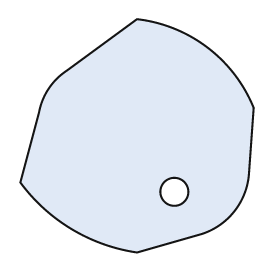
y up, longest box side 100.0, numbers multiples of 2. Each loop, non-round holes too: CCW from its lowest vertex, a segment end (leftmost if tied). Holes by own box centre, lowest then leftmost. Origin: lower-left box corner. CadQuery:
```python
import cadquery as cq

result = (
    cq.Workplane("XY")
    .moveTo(50.0, 0.0)
    .lineTo(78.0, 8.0)
    .threePointArc((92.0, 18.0), (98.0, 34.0))
    .lineTo(100.0, 62.0)
    .threePointArc((80.0, 88.0), (50.0, 100.0))
    .lineTo(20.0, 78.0)
    .threePointArc((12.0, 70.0), (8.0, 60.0))
    .lineTo(0.0, 30.0)
    .threePointArc((22.0, 10.0), (50.0, 0.0))
    .close()
    .moveTo(66.0, 26.0)
    .circle(6.0)
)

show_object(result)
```